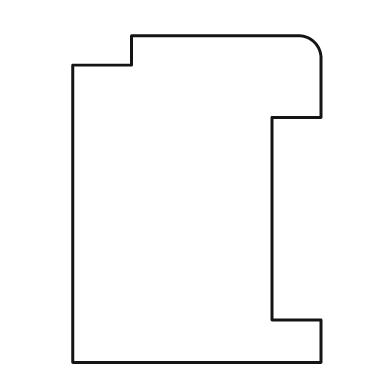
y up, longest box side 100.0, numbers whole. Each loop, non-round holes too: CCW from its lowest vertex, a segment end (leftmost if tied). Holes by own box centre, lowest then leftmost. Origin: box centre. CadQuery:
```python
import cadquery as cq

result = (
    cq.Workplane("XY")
    .moveTo(-38.0, -50.0)
    .lineTo(38.0, -50.0)
    .lineTo(38.0, -37.0)
    .lineTo(23.0, -37.0)
    .lineTo(23.0, 25.0)
    .lineTo(38.0, 25.0)
    .lineTo(38.0, 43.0)
    .threePointArc((36.0, 48.0), (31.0, 50.0))
    .lineTo(-20.0, 50.0)
    .lineTo(-20.0, 41.0)
    .lineTo(-38.0, 41.0)
    .close()
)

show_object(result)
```